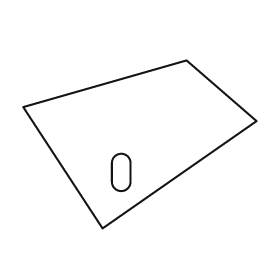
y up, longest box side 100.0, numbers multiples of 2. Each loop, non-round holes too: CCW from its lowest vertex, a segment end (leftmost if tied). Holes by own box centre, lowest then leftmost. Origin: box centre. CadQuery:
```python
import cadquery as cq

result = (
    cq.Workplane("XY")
    .moveTo(-16.0, -36.0)
    .lineTo(50.0, 10.0)
    .lineTo(20.0, 36.0)
    .lineTo(-50.0, 16.0)
    .close()
    .moveTo(-12.0, -16.0)
    .threePointArc((-8.0, -20.0), (-4.0, -16.0))
    .lineTo(-4.0, -8.0)
    .threePointArc((-8.0, -4.0), (-12.0, -8.0))
    .close()
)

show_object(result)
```